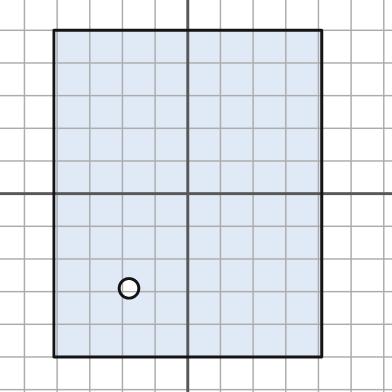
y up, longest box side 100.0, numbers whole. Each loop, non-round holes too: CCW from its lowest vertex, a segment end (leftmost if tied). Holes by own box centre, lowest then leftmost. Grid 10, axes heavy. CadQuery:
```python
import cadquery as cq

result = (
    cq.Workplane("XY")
    .moveTo(-41.0, -50.0)
    .lineTo(41.0, -50.0)
    .lineTo(41.0, 50.0)
    .lineTo(-41.0, 50.0)
    .close()
    .moveTo(-18.0, -29.0)
    .circle(3.0)
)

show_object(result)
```